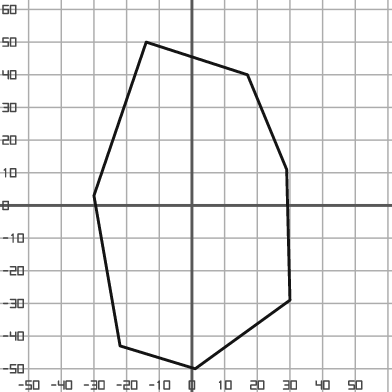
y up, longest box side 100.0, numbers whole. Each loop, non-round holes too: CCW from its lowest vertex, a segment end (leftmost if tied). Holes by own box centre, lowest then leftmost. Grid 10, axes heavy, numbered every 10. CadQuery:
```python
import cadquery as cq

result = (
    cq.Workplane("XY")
    .moveTo(1.0, -50.0)
    .lineTo(30.0, -29.0)
    .lineTo(29.0, 11.0)
    .lineTo(17.0, 40.0)
    .lineTo(-14.0, 50.0)
    .lineTo(-30.0, 3.0)
    .lineTo(-22.0, -43.0)
    .close()
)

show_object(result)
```